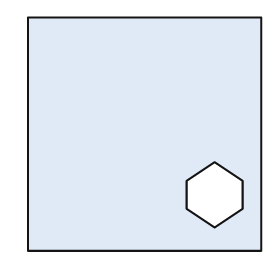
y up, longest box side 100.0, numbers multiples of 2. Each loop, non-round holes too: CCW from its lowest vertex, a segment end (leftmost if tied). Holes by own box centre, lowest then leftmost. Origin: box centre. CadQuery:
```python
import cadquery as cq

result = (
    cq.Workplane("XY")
    .moveTo(-50.0, -50.0)
    .lineTo(50.0, -50.0)
    .lineTo(50.0, 50.0)
    .lineTo(-50.0, 50.0)
    .close()
    .moveTo(30.0, -40.0)
    .lineTo(42.0, -32.0)
    .lineTo(42.0, -20.0)
    .lineTo(30.0, -12.0)
    .lineTo(18.0, -20.0)
    .lineTo(18.0, -32.0)
    .close()
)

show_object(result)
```